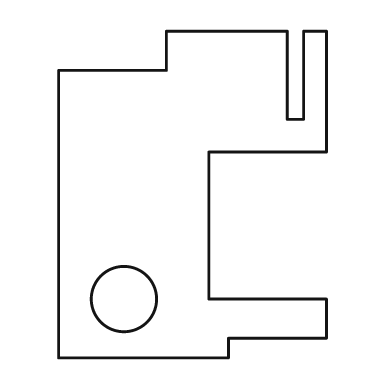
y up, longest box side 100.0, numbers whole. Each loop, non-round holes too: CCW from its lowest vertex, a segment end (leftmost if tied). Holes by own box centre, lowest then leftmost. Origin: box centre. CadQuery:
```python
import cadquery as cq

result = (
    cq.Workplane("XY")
    .moveTo(-41.0, -50.0)
    .lineTo(11.0, -50.0)
    .lineTo(11.0, -44.0)
    .lineTo(41.0, -44.0)
    .lineTo(41.0, -32.0)
    .lineTo(5.0, -32.0)
    .lineTo(5.0, 13.0)
    .lineTo(41.0, 13.0)
    .lineTo(41.0, 50.0)
    .lineTo(34.0, 50.0)
    .lineTo(34.0, 23.0)
    .lineTo(29.0, 23.0)
    .lineTo(29.0, 50.0)
    .lineTo(-8.0, 50.0)
    .lineTo(-8.0, 38.0)
    .lineTo(-41.0, 38.0)
    .close()
    .moveTo(-21.0, -32.0)
    .circle(10.0)
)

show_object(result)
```